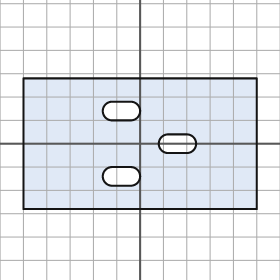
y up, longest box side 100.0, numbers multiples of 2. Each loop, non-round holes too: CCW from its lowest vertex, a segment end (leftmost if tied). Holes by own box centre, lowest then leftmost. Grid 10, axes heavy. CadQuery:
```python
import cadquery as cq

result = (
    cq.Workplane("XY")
    .moveTo(-50.0, -28.0)
    .lineTo(50.0, -28.0)
    .lineTo(50.0, 28.0)
    .lineTo(-50.0, 28.0)
    .close()
    .moveTo(-12.0, -18.0)
    .lineTo(-4.0, -18.0)
    .threePointArc((0.0, -14.0), (-4.0, -10.0))
    .lineTo(-12.0, -10.0)
    .threePointArc((-16.0, -14.0), (-12.0, -18.0))
    .close()
    .moveTo(12.0, -4.0)
    .lineTo(20.0, -4.0)
    .threePointArc((24.0, 0.0), (20.0, 4.0))
    .lineTo(12.0, 4.0)
    .threePointArc((8.0, 0.0), (12.0, -4.0))
    .close()
    .moveTo(-12.0, 10.0)
    .lineTo(-4.0, 10.0)
    .threePointArc((0.0, 14.0), (-4.0, 18.0))
    .lineTo(-12.0, 18.0)
    .threePointArc((-16.0, 14.0), (-12.0, 10.0))
    .close()
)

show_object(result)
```